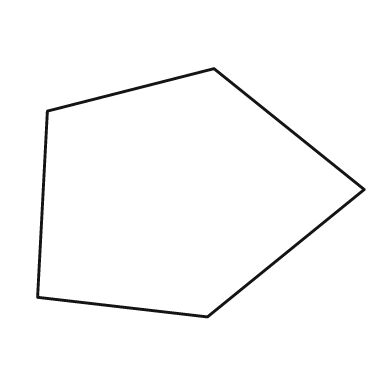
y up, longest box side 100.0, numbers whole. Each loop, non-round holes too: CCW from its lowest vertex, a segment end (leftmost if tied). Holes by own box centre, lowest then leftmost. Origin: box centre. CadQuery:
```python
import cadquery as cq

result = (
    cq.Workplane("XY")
    .moveTo(2.0, -38.0)
    .lineTo(50.0, 1.0)
    .lineTo(4.0, 38.0)
    .lineTo(-47.0, 25.0)
    .lineTo(-50.0, -32.0)
    .close()
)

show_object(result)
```